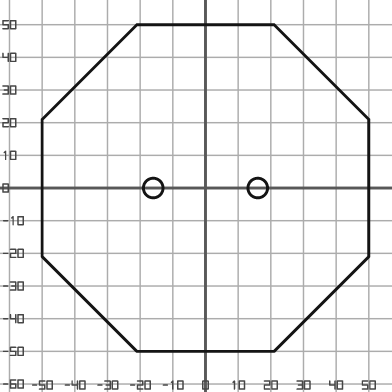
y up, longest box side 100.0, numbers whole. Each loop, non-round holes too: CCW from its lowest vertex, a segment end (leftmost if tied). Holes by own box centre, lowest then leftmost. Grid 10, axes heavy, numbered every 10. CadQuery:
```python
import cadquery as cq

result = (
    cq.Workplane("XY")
    .moveTo(-21.0, -50.0)
    .lineTo(21.0, -50.0)
    .lineTo(50.0, -21.0)
    .lineTo(50.0, 21.0)
    .lineTo(21.0, 50.0)
    .lineTo(-21.0, 50.0)
    .lineTo(-50.0, 21.0)
    .lineTo(-50.0, -21.0)
    .close()
    .moveTo(-16.0, 0.0)
    .circle(3.0)
    .moveTo(16.0, 0.0)
    .circle(3.0)
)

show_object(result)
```